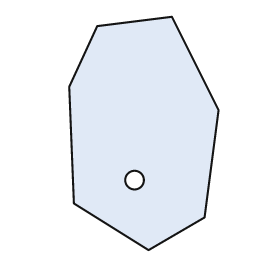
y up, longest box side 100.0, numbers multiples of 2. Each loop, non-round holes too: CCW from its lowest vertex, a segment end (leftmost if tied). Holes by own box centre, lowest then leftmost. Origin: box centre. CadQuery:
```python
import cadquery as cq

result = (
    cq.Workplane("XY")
    .moveTo(2.0, -50.0)
    .lineTo(26.0, -36.0)
    .lineTo(32.0, 10.0)
    .lineTo(12.0, 50.0)
    .lineTo(-20.0, 46.0)
    .lineTo(-32.0, 20.0)
    .lineTo(-30.0, -30.0)
    .close()
    .moveTo(-4.0, -20.0)
    .circle(4.0)
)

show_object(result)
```